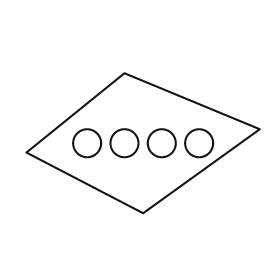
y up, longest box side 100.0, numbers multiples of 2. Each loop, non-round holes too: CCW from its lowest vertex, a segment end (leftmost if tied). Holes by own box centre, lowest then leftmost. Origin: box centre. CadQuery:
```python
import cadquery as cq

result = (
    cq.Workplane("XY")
    .moveTo(0.0, -30.0)
    .lineTo(50.0, 6.0)
    .lineTo(-8.0, 30.0)
    .lineTo(-50.0, -4.0)
    .close()
    .moveTo(-24.0, 0.0)
    .circle(6.0)
    .moveTo(-8.0, 0.0)
    .circle(6.0)
    .moveTo(8.0, 0.0)
    .circle(6.0)
    .moveTo(24.0, 0.0)
    .circle(6.0)
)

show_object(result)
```